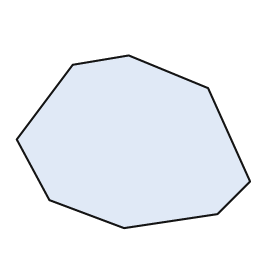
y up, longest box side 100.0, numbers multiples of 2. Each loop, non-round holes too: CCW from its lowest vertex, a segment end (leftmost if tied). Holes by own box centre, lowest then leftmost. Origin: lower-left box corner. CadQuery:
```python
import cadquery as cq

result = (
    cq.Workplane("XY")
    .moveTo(46.0, 0.0)
    .lineTo(86.0, 6.0)
    .lineTo(100.0, 20.0)
    .lineTo(82.0, 60.0)
    .lineTo(48.0, 74.0)
    .lineTo(24.0, 70.0)
    .lineTo(0.0, 38.0)
    .lineTo(14.0, 12.0)
    .close()
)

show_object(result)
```